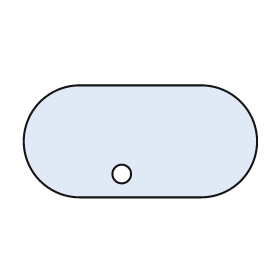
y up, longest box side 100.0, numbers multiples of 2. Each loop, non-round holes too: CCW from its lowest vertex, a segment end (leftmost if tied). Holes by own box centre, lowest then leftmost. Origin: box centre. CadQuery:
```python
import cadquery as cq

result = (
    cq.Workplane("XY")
    .moveTo(-26.0, -24.0)
    .lineTo(26.0, -24.0)
    .threePointArc((50.0, 0.0), (26.0, 24.0))
    .lineTo(-26.0, 24.0)
    .threePointArc((-50.0, 0.0), (-26.0, -24.0))
    .close()
    .moveTo(-8.0, -14.0)
    .circle(4.0)
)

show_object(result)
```